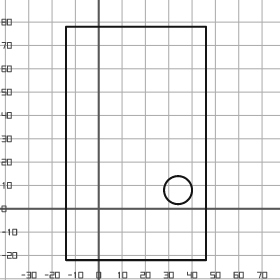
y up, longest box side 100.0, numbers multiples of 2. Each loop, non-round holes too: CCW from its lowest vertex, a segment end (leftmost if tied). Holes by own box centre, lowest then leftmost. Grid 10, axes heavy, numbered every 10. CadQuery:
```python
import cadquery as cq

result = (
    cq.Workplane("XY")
    .moveTo(-14.0, -22.0)
    .lineTo(46.0, -22.0)
    .lineTo(46.0, 78.0)
    .lineTo(-14.0, 78.0)
    .close()
    .moveTo(34.0, 8.0)
    .circle(6.0)
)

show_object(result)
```